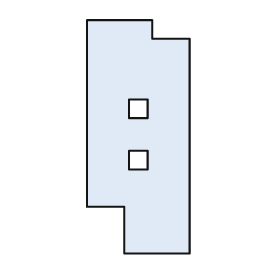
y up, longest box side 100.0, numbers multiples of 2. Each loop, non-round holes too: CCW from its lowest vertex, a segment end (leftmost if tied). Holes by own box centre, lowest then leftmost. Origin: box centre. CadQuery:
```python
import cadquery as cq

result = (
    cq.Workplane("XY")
    .moveTo(-6.0, -50.0)
    .lineTo(22.0, -50.0)
    .lineTo(22.0, 42.0)
    .lineTo(6.0, 42.0)
    .lineTo(6.0, 50.0)
    .lineTo(-22.0, 50.0)
    .lineTo(-22.0, -30.0)
    .lineTo(-6.0, -30.0)
    .close()
    .moveTo(-4.0, -14.0)
    .lineTo(4.0, -14.0)
    .lineTo(4.0, -6.0)
    .lineTo(-4.0, -6.0)
    .close()
    .moveTo(-4.0, 8.0)
    .lineTo(4.0, 8.0)
    .lineTo(4.0, 16.0)
    .lineTo(-4.0, 16.0)
    .close()
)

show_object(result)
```